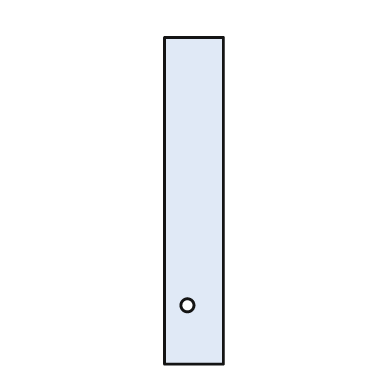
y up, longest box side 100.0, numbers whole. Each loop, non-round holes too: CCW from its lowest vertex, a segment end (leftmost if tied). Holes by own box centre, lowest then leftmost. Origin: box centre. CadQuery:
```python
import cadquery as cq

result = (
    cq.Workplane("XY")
    .moveTo(-9.0, -50.0)
    .lineTo(9.0, -50.0)
    .lineTo(9.0, 50.0)
    .lineTo(-9.0, 50.0)
    .close()
    .moveTo(-2.0, -32.0)
    .circle(2.0)
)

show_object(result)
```